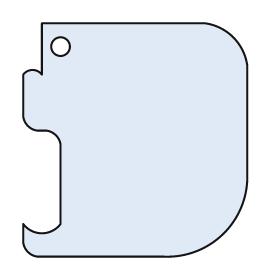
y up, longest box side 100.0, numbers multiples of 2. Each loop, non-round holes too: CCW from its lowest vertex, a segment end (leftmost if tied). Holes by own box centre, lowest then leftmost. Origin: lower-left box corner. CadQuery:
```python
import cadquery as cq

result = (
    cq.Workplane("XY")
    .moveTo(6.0, 0.0)
    .lineTo(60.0, 0.0)
    .threePointArc((86.0, 10.0), (96.0, 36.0))
    .lineTo(96.0, 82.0)
    .threePointArc((90.0, 94.0), (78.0, 100.0))
    .lineTo(8.0, 100.0)
    .lineTo(8.0, 78.0)
    .threePointArc((4.0, 80.0), (0.0, 78.0))
    .lineTo(0.0, 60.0)
    .threePointArc((2.0, 56.0), (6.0, 54.0))
    .lineTo(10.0, 54.0)
    .threePointArc((14.0, 52.0), (16.0, 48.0))
    .lineTo(16.0, 14.0)
    .threePointArc((8.0, 10.0), (0.0, 14.0))
    .lineTo(0.0, 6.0)
    .threePointArc((2.0, 2.0), (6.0, 0.0))
    .close()
    .moveTo(16.0, 90.0)
    .circle(4.0)
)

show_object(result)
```